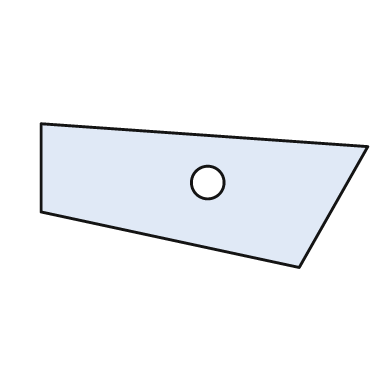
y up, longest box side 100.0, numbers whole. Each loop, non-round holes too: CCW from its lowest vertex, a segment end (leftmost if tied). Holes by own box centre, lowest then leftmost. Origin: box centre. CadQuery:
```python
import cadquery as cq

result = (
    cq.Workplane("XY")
    .moveTo(29.0, -22.0)
    .lineTo(50.0, 15.0)
    .lineTo(-50.0, 22.0)
    .lineTo(-50.0, -5.0)
    .close()
    .moveTo(1.0, 4.0)
    .circle(5.0)
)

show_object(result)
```